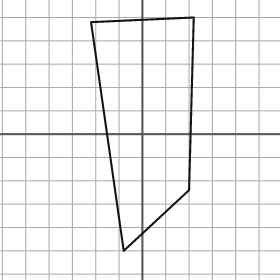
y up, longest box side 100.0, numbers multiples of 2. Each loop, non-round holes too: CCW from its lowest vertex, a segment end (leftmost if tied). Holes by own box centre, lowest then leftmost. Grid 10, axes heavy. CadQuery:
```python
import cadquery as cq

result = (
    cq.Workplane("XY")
    .moveTo(-8.0, -50.0)
    .lineTo(20.0, -24.0)
    .lineTo(22.0, 50.0)
    .lineTo(-22.0, 48.0)
    .close()
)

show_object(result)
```